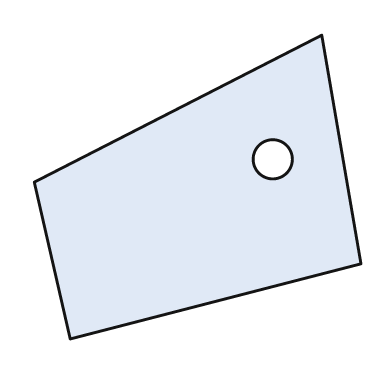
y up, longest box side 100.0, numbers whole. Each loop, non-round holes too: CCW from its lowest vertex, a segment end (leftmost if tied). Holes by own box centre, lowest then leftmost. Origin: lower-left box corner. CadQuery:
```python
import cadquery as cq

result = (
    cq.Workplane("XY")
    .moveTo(11.0, 0.0)
    .lineTo(100.0, 23.0)
    .lineTo(88.0, 93.0)
    .lineTo(0.0, 48.0)
    .close()
    .moveTo(73.0, 55.0)
    .circle(6.0)
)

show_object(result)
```